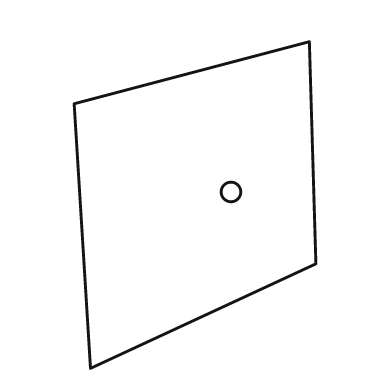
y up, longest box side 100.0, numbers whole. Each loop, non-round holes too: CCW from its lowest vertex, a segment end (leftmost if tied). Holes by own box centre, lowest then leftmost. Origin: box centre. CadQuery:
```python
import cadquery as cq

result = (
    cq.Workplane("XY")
    .moveTo(-32.0, -50.0)
    .lineTo(37.0, -18.0)
    .lineTo(35.0, 50.0)
    .lineTo(-37.0, 31.0)
    .close()
    .moveTo(11.0, 4.0)
    .circle(3.0)
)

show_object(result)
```